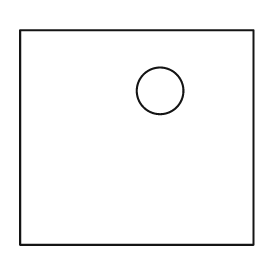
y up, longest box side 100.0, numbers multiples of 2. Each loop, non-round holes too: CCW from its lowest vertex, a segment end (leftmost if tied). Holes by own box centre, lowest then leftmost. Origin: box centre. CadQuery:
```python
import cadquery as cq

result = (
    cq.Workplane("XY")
    .moveTo(-50.0, -46.0)
    .lineTo(50.0, -46.0)
    .lineTo(50.0, 46.0)
    .lineTo(-50.0, 46.0)
    .close()
    .moveTo(10.0, 20.0)
    .circle(10.0)
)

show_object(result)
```